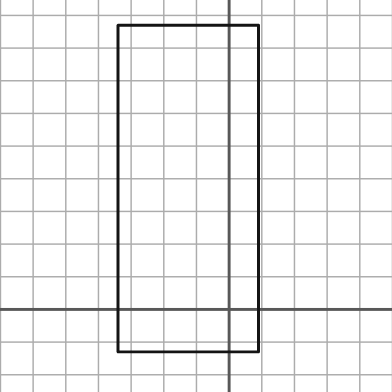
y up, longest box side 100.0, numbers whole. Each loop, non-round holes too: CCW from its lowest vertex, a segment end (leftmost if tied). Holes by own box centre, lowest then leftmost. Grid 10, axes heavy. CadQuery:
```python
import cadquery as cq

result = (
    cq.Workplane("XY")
    .moveTo(-34.0, -13.0)
    .lineTo(9.0, -13.0)
    .lineTo(9.0, 87.0)
    .lineTo(-34.0, 87.0)
    .close()
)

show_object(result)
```